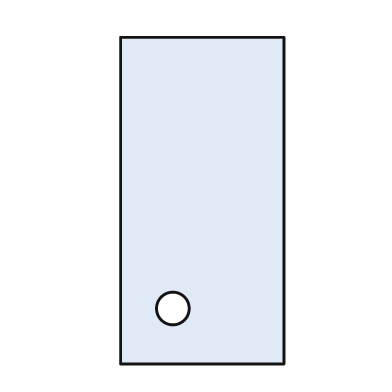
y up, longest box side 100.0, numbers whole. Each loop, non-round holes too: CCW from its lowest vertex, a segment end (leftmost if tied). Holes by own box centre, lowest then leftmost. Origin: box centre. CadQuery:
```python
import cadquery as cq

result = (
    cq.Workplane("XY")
    .moveTo(-25.0, -50.0)
    .lineTo(25.0, -50.0)
    .lineTo(25.0, 50.0)
    .lineTo(-25.0, 50.0)
    .close()
    .moveTo(-9.0, -33.0)
    .circle(5.0)
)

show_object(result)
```